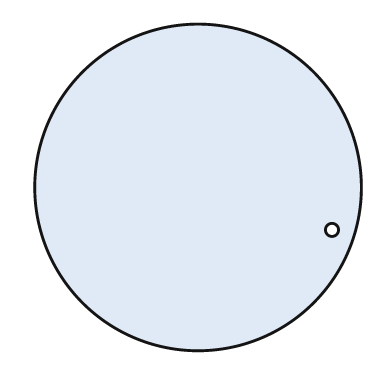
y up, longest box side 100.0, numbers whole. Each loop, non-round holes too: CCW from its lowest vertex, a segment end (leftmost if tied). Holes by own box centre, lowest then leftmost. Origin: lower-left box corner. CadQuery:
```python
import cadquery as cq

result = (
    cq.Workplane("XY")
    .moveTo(50.0, 50.0)
    .circle(50.0)
    .moveTo(91.0, 37.0)
    .circle(2.0)
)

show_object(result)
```